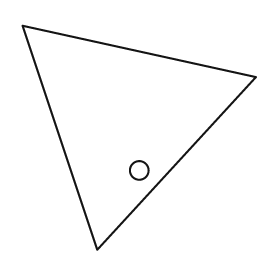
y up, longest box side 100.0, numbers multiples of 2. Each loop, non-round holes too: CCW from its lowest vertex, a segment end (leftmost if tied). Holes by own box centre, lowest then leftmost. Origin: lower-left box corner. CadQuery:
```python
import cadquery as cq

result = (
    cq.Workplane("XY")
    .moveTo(32.0, 0.0)
    .lineTo(100.0, 74.0)
    .lineTo(0.0, 96.0)
    .close()
    .moveTo(50.0, 34.0)
    .circle(4.0)
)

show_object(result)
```